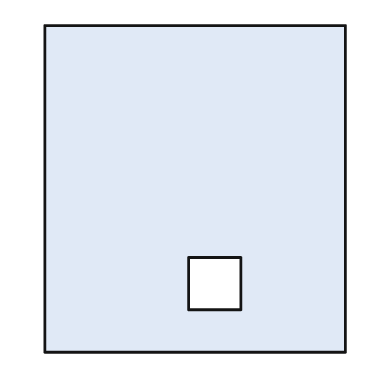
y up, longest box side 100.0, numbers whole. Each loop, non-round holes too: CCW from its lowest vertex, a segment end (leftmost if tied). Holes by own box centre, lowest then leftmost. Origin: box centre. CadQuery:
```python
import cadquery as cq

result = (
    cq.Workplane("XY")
    .moveTo(-46.0, -50.0)
    .lineTo(46.0, -50.0)
    .lineTo(46.0, 50.0)
    .lineTo(-46.0, 50.0)
    .close()
    .moveTo(-2.0, -37.0)
    .lineTo(14.0, -37.0)
    .lineTo(14.0, -21.0)
    .lineTo(-2.0, -21.0)
    .close()
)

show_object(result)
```